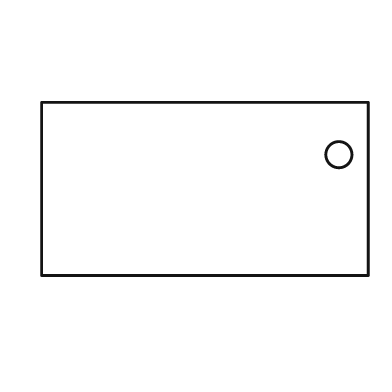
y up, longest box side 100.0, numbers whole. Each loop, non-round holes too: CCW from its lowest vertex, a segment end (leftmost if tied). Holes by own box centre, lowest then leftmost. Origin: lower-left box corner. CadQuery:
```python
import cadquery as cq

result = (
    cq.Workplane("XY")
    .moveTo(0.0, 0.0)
    .lineTo(100.0, 0.0)
    .lineTo(100.0, 53.0)
    .lineTo(0.0, 53.0)
    .close()
    .moveTo(91.0, 37.0)
    .circle(4.0)
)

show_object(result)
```